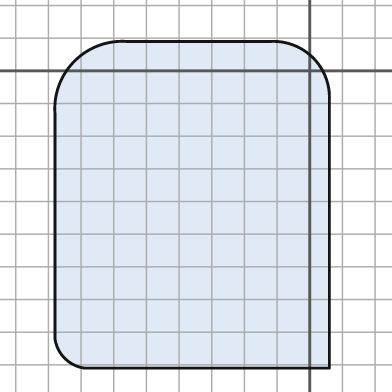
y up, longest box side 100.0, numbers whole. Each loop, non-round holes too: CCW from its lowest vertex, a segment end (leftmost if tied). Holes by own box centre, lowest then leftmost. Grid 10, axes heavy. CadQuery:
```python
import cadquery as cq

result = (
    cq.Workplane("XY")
    .moveTo(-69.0, -91.0)
    .lineTo(6.0, -91.0)
    .lineTo(6.0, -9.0)
    .threePointArc((1.0, 4.0), (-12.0, 9.0))
    .lineTo(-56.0, 9.0)
    .threePointArc((-72.0, 3.0), (-78.0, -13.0))
    .lineTo(-78.0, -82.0)
    .threePointArc((-75.0, -88.0), (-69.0, -91.0))
    .close()
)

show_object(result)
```